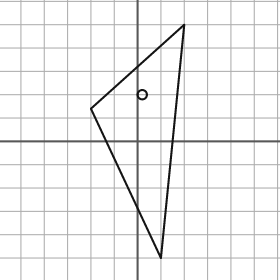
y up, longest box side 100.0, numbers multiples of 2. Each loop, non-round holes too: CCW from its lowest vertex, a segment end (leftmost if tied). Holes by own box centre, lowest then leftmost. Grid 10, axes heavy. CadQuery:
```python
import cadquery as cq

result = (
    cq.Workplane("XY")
    .moveTo(10.0, -50.0)
    .lineTo(20.0, 50.0)
    .lineTo(-20.0, 14.0)
    .close()
    .moveTo(2.0, 20.0)
    .circle(2.0)
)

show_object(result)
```